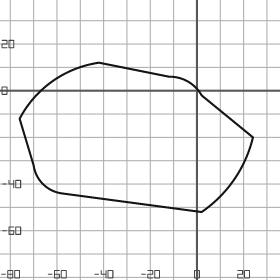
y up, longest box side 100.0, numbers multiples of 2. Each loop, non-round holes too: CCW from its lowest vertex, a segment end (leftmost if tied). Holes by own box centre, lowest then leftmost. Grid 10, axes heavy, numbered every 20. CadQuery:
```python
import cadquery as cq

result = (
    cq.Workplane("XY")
    .moveTo(2.0, -52.0)
    .threePointArc((16.0, -38.0), (24.0, -20.0))
    .lineTo(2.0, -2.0)
    .threePointArc((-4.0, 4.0), (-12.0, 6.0))
    .lineTo(-42.0, 12.0)
    .threePointArc((-62.0, 4.0), (-76.0, -12.0))
    .lineTo(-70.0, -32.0)
    .threePointArc((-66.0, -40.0), (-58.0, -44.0))
    .close()
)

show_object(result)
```